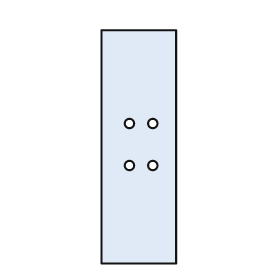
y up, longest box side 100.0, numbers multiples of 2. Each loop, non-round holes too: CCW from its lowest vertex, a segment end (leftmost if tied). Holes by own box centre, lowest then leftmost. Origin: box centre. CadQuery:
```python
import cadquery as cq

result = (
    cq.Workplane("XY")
    .moveTo(-16.0, -50.0)
    .lineTo(16.0, -50.0)
    .lineTo(16.0, 50.0)
    .lineTo(-16.0, 50.0)
    .close()
    .moveTo(-4.0, -8.0)
    .circle(2.0)
    .moveTo(6.0, -8.0)
    .circle(2.0)
    .moveTo(-4.0, 10.0)
    .circle(2.0)
    .moveTo(6.0, 10.0)
    .circle(2.0)
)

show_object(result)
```